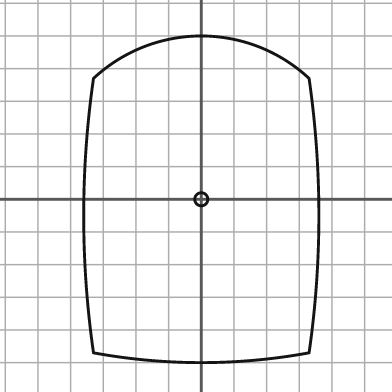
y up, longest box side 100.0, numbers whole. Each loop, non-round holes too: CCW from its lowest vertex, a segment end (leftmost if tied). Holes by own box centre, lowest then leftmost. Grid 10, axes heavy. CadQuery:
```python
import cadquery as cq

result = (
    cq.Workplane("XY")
    .moveTo(-33.0, -47.0)
    .threePointArc((0.0, -50.0), (33.0, -47.0))
    .threePointArc((36.0, -5.0), (33.0, 37.0))
    .threePointArc((0.0, 50.0), (-33.0, 37.0))
    .threePointArc((-36.0, -5.0), (-33.0, -47.0))
    .close()
    .moveTo(0.0, 0.0)
    .circle(2.0)
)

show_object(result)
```